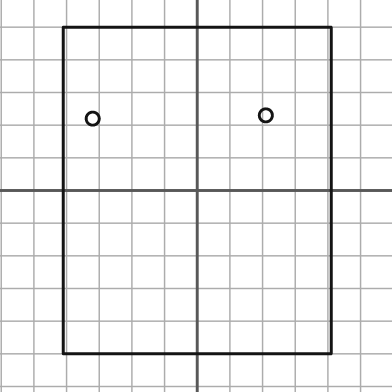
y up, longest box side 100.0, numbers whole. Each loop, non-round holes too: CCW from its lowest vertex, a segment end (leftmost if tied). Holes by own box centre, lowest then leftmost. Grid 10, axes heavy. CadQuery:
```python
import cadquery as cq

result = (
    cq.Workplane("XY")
    .moveTo(-41.0, -50.0)
    .lineTo(41.0, -50.0)
    .lineTo(41.0, 50.0)
    .lineTo(-41.0, 50.0)
    .close()
    .moveTo(-32.0, 22.0)
    .circle(2.0)
    .moveTo(21.0, 23.0)
    .circle(2.0)
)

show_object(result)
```